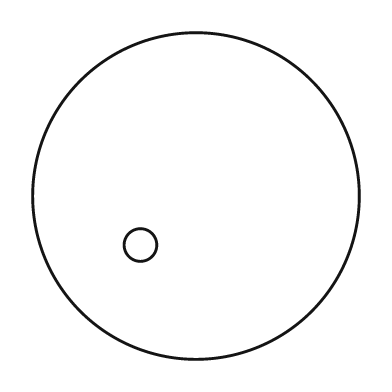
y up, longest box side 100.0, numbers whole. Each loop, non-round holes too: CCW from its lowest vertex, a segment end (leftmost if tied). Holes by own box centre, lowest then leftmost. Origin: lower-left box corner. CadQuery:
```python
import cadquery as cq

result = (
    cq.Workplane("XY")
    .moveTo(50.0, 50.0)
    .circle(50.0)
    .moveTo(33.0, 35.0)
    .circle(5.0)
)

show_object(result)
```